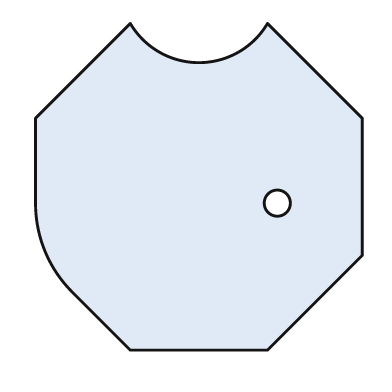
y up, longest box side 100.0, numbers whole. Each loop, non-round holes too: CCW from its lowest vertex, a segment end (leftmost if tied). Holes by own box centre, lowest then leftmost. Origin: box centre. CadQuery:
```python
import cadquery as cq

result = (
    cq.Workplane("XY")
    .moveTo(-21.0, -50.0)
    .lineTo(21.0, -50.0)
    .lineTo(50.0, -21.0)
    .lineTo(50.0, 21.0)
    .lineTo(21.0, 50.0)
    .threePointArc((0.0, 38.0), (-21.0, 50.0))
    .lineTo(-50.0, 21.0)
    .lineTo(-50.0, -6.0)
    .threePointArc((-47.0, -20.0), (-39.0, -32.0))
    .close()
    .moveTo(24.0, -5.0)
    .circle(4.0)
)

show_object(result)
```